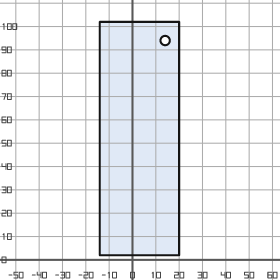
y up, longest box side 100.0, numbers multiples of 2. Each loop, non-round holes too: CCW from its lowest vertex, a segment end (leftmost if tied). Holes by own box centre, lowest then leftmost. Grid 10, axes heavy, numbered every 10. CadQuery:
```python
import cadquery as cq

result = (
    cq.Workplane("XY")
    .moveTo(-14.0, 2.0)
    .lineTo(20.0, 2.0)
    .lineTo(20.0, 102.0)
    .lineTo(-14.0, 102.0)
    .close()
    .moveTo(14.0, 94.0)
    .circle(2.0)
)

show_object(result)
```